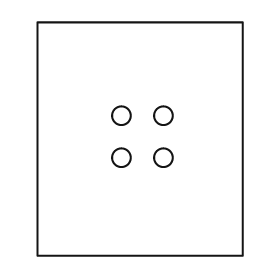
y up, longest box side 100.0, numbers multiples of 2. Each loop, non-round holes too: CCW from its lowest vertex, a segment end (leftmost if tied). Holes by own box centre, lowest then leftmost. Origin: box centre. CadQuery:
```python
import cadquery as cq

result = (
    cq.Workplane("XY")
    .moveTo(-44.0, -50.0)
    .lineTo(44.0, -50.0)
    .lineTo(44.0, 50.0)
    .lineTo(-44.0, 50.0)
    .close()
    .moveTo(-8.0, -8.0)
    .circle(4.0)
    .moveTo(10.0, -8.0)
    .circle(4.0)
    .moveTo(-8.0, 10.0)
    .circle(4.0)
    .moveTo(10.0, 10.0)
    .circle(4.0)
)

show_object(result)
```